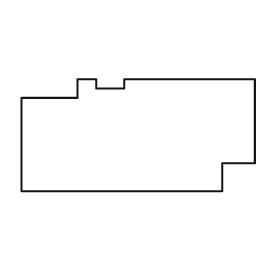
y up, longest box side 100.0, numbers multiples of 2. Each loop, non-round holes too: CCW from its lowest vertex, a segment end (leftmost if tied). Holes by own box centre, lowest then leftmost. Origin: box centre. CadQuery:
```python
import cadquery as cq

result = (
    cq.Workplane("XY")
    .moveTo(-50.0, -24.0)
    .lineTo(36.0, -24.0)
    .lineTo(36.0, -12.0)
    .lineTo(50.0, -12.0)
    .lineTo(50.0, 24.0)
    .lineTo(-6.0, 24.0)
    .lineTo(-6.0, 20.0)
    .lineTo(-18.0, 20.0)
    .lineTo(-18.0, 24.0)
    .lineTo(-26.0, 24.0)
    .lineTo(-26.0, 16.0)
    .lineTo(-50.0, 16.0)
    .close()
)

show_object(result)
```